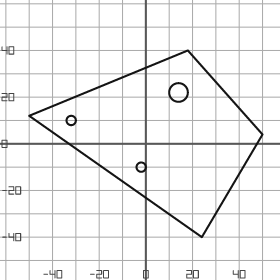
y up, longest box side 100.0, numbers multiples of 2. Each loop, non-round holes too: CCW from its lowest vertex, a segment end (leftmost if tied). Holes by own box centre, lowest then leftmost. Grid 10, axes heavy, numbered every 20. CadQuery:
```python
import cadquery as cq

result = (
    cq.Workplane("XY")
    .moveTo(24.0, -40.0)
    .lineTo(50.0, 4.0)
    .lineTo(18.0, 40.0)
    .lineTo(-50.0, 12.0)
    .close()
    .moveTo(-2.0, -10.0)
    .circle(2.0)
    .moveTo(-32.0, 10.0)
    .circle(2.0)
    .moveTo(14.0, 22.0)
    .circle(4.0)
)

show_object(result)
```